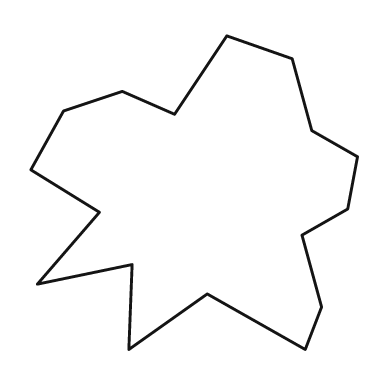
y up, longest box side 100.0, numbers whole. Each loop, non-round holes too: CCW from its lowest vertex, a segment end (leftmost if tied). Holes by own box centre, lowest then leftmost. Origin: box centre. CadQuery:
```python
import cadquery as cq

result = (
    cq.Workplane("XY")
    .moveTo(-20.0, -48.0)
    .lineTo(4.0, -31.0)
    .lineTo(34.0, -48.0)
    .lineTo(39.0, -35.0)
    .lineTo(33.0, -13.0)
    .lineTo(47.0, -5.0)
    .lineTo(50.0, 11.0)
    .lineTo(36.0, 19.0)
    .lineTo(30.0, 41.0)
    .lineTo(10.0, 48.0)
    .lineTo(-6.0, 24.0)
    .lineTo(-22.0, 31.0)
    .lineTo(-40.0, 25.0)
    .lineTo(-50.0, 7.0)
    .lineTo(-29.0, -6.0)
    .lineTo(-48.0, -28.0)
    .lineTo(-19.0, -22.0)
    .close()
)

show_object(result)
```